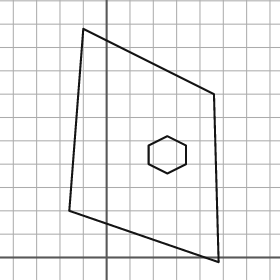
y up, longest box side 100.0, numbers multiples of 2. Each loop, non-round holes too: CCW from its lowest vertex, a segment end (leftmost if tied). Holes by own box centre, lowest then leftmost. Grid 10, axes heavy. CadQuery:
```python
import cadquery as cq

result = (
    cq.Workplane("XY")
    .moveTo(48.0, -2.0)
    .lineTo(46.0, 70.0)
    .lineTo(-10.0, 98.0)
    .lineTo(-16.0, 20.0)
    .close()
    .moveTo(26.0, 36.0)
    .lineTo(34.0, 40.0)
    .lineTo(34.0, 48.0)
    .lineTo(26.0, 52.0)
    .lineTo(18.0, 48.0)
    .lineTo(18.0, 40.0)
    .close()
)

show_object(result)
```